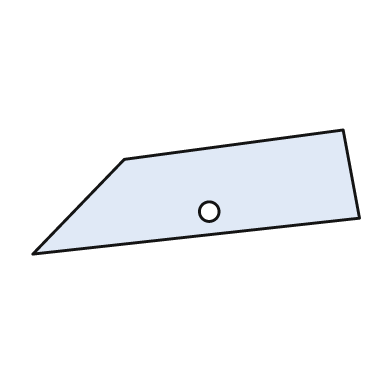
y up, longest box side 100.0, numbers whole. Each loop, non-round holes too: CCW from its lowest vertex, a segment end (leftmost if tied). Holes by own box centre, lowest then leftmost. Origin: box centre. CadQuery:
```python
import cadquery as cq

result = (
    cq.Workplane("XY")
    .moveTo(-50.0, -19.0)
    .lineTo(50.0, -8.0)
    .lineTo(45.0, 19.0)
    .lineTo(-22.0, 10.0)
    .close()
    .moveTo(4.0, -6.0)
    .circle(3.0)
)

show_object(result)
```